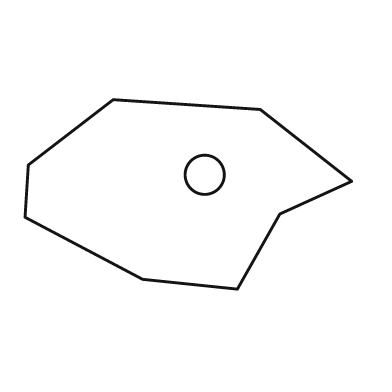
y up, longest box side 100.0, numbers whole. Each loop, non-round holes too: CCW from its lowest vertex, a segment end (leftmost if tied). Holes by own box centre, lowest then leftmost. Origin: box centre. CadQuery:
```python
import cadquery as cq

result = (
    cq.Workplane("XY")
    .moveTo(15.0, -29.0)
    .lineTo(28.0, -6.0)
    .lineTo(50.0, 4.0)
    .lineTo(22.0, 26.0)
    .lineTo(-23.0, 29.0)
    .lineTo(-49.0, 9.0)
    .lineTo(-50.0, -7.0)
    .lineTo(-14.0, -26.0)
    .close()
    .moveTo(5.0, 6.0)
    .circle(6.0)
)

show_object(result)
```